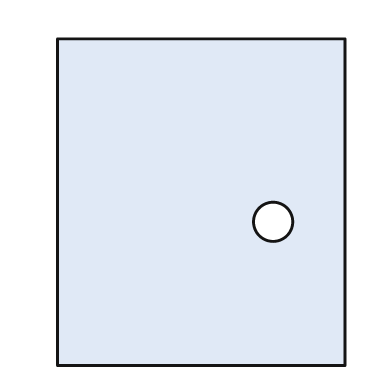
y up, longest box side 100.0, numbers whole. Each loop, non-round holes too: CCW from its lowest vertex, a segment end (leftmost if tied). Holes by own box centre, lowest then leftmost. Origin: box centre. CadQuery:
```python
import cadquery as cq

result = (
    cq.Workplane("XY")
    .moveTo(-44.0, -50.0)
    .lineTo(44.0, -50.0)
    .lineTo(44.0, 50.0)
    .lineTo(-44.0, 50.0)
    .close()
    .moveTo(22.0, -6.0)
    .circle(6.0)
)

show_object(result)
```